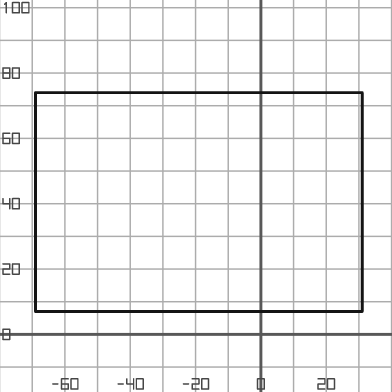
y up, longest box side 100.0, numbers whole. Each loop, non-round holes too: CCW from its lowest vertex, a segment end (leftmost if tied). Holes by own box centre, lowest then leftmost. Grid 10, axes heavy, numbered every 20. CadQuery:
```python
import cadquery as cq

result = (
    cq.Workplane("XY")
    .moveTo(-69.0, 7.0)
    .lineTo(31.0, 7.0)
    .lineTo(31.0, 74.0)
    .lineTo(-69.0, 74.0)
    .close()
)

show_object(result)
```